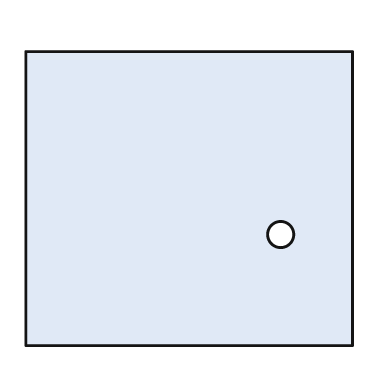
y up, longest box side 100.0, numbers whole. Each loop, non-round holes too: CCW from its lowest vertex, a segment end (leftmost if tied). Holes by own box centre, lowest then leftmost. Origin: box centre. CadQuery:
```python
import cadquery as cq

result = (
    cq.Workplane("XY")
    .moveTo(-50.0, -45.0)
    .lineTo(50.0, -45.0)
    .lineTo(50.0, 45.0)
    .lineTo(-50.0, 45.0)
    .close()
    .moveTo(28.0, -11.0)
    .circle(4.0)
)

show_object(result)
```